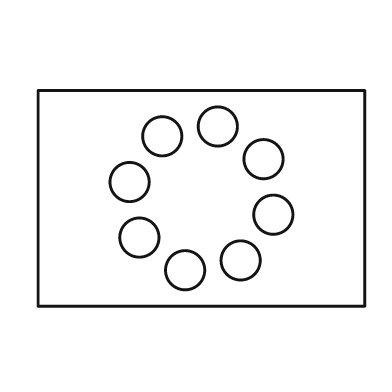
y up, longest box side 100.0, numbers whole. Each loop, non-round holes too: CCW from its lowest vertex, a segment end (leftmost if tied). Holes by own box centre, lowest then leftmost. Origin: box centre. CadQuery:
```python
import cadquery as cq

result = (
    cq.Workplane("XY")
    .moveTo(-50.0, -33.0)
    .lineTo(50.0, -33.0)
    .lineTo(50.0, 33.0)
    .lineTo(-50.0, 33.0)
    .close()
    .moveTo(-5.0, -22.0)
    .circle(6.0)
    .moveTo(12.0, -19.0)
    .circle(6.0)
    .moveTo(-19.0, -12.0)
    .circle(6.0)
    .moveTo(22.0, -5.0)
    .circle(6.0)
    .moveTo(-22.0, 5.0)
    .circle(6.0)
    .moveTo(19.0, 12.0)
    .circle(6.0)
    .moveTo(-12.0, 19.0)
    .circle(6.0)
    .moveTo(5.0, 22.0)
    .circle(6.0)
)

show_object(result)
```